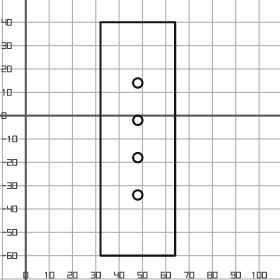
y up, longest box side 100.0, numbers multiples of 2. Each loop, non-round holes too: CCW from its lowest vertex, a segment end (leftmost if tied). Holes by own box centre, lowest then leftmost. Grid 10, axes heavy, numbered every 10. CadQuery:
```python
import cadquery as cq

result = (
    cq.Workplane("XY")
    .moveTo(32.0, -60.0)
    .lineTo(64.0, -60.0)
    .lineTo(64.0, 40.0)
    .lineTo(32.0, 40.0)
    .close()
    .moveTo(48.0, -34.0)
    .circle(2.0)
    .moveTo(48.0, -18.0)
    .circle(2.0)
    .moveTo(48.0, -2.0)
    .circle(2.0)
    .moveTo(48.0, 14.0)
    .circle(2.0)
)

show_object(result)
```